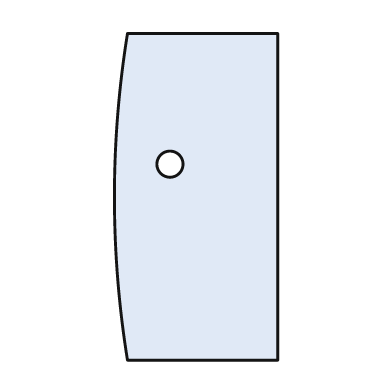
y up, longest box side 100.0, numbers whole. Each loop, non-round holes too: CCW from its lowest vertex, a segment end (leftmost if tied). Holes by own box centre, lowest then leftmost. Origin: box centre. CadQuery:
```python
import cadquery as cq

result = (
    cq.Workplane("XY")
    .moveTo(-21.0, -50.0)
    .lineTo(25.0, -50.0)
    .lineTo(25.0, 50.0)
    .lineTo(-21.0, 50.0)
    .threePointArc((-25.0, 0.0), (-21.0, -50.0))
    .close()
    .moveTo(-8.0, 10.0)
    .circle(4.0)
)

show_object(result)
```